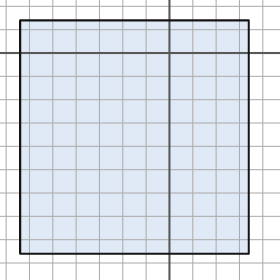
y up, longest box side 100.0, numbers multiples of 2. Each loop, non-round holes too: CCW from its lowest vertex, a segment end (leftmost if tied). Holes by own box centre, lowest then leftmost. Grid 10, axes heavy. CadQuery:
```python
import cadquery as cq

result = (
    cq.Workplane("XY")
    .moveTo(-64.0, -86.0)
    .lineTo(34.0, -86.0)
    .lineTo(34.0, 14.0)
    .lineTo(-64.0, 14.0)
    .close()
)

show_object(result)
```